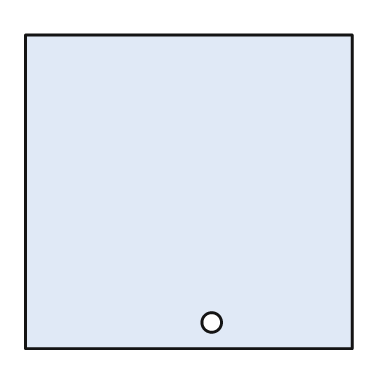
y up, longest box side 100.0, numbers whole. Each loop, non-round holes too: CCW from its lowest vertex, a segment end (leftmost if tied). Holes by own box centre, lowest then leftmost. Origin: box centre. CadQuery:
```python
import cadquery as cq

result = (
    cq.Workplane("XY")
    .moveTo(-50.0, -48.0)
    .lineTo(50.0, -48.0)
    .lineTo(50.0, 48.0)
    .lineTo(-50.0, 48.0)
    .close()
    .moveTo(7.0, -40.0)
    .circle(3.0)
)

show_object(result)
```